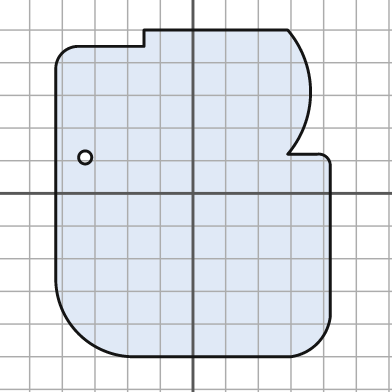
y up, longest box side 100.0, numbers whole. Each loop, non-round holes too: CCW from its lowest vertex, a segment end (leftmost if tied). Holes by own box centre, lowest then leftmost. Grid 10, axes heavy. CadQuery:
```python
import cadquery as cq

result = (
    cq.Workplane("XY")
    .moveTo(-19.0, -50.0)
    .lineTo(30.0, -50.0)
    .threePointArc((38.0, -46.0), (42.0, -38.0))
    .lineTo(42.0, 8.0)
    .threePointArc((41.0, 11.0), (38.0, 12.0))
    .lineTo(29.0, 12.0)
    .threePointArc((36.0, 31.0), (29.0, 50.0))
    .lineTo(-15.0, 50.0)
    .lineTo(-15.0, 45.0)
    .lineTo(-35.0, 45.0)
    .threePointArc((-40.0, 43.0), (-42.0, 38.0))
    .lineTo(-42.0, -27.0)
    .threePointArc((-35.0, -43.0), (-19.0, -50.0))
    .close()
    .moveTo(-33.0, 11.0)
    .circle(2.0)
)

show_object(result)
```